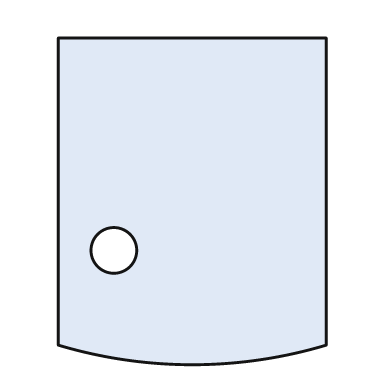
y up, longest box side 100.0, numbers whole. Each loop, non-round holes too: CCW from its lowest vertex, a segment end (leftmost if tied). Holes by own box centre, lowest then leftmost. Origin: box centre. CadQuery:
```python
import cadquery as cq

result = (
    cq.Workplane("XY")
    .moveTo(-41.0, -44.0)
    .threePointArc((0.0, -50.0), (41.0, -44.0))
    .lineTo(41.0, 50.0)
    .lineTo(-41.0, 50.0)
    .close()
    .moveTo(-24.0, -15.0)
    .circle(7.0)
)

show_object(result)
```